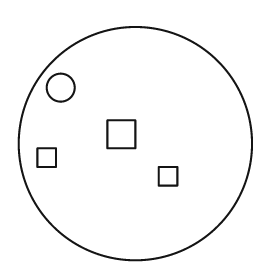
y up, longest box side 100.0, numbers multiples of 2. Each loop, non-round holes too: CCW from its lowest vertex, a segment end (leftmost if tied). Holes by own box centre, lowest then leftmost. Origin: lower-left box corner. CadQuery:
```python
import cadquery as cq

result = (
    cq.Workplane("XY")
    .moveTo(50.0, 50.0)
    .circle(50.0)
    .moveTo(60.0, 32.0)
    .lineTo(68.0, 32.0)
    .lineTo(68.0, 40.0)
    .lineTo(60.0, 40.0)
    .close()
    .moveTo(8.0, 40.0)
    .lineTo(16.0, 40.0)
    .lineTo(16.0, 48.0)
    .lineTo(8.0, 48.0)
    .close()
    .moveTo(38.0, 48.0)
    .lineTo(50.0, 48.0)
    .lineTo(50.0, 60.0)
    .lineTo(38.0, 60.0)
    .close()
    .moveTo(18.0, 74.0)
    .circle(6.0)
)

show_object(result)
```